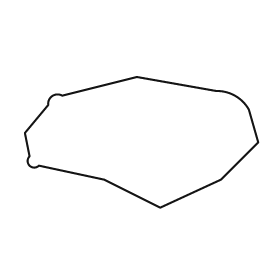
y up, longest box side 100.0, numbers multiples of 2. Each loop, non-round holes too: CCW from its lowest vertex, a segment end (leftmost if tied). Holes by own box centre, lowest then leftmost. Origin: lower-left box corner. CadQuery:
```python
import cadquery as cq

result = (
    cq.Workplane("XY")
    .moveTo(58.0, 0.0)
    .lineTo(84.0, 12.0)
    .lineTo(100.0, 28.0)
    .lineTo(96.0, 42.0)
    .threePointArc((90.0, 48.0), (82.0, 50.0))
    .lineTo(48.0, 56.0)
    .lineTo(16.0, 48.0)
    .threePointArc((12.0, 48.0), (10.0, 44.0))
    .lineTo(0.0, 32.0)
    .lineTo(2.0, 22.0)
    .threePointArc((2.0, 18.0), (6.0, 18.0))
    .lineTo(34.0, 12.0)
    .close()
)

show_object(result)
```